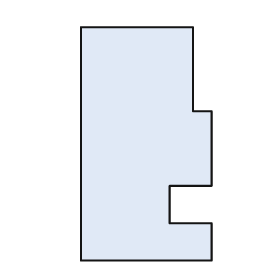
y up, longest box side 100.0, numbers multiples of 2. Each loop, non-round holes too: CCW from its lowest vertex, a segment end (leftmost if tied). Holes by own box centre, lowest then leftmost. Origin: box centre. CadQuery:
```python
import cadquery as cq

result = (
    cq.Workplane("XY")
    .moveTo(-28.0, -50.0)
    .lineTo(28.0, -50.0)
    .lineTo(28.0, -34.0)
    .lineTo(10.0, -34.0)
    .lineTo(10.0, -18.0)
    .lineTo(28.0, -18.0)
    .lineTo(28.0, 14.0)
    .lineTo(20.0, 14.0)
    .lineTo(20.0, 50.0)
    .lineTo(-28.0, 50.0)
    .close()
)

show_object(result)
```